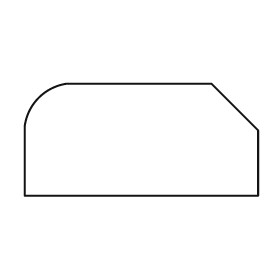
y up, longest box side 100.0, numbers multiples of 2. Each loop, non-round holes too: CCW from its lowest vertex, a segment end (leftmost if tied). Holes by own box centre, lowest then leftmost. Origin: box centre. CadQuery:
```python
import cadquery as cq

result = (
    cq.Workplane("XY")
    .moveTo(-50.0, -24.0)
    .lineTo(50.0, -24.0)
    .lineTo(50.0, 4.0)
    .lineTo(30.0, 24.0)
    .lineTo(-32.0, 24.0)
    .threePointArc((-44.0, 18.0), (-50.0, 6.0))
    .close()
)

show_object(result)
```